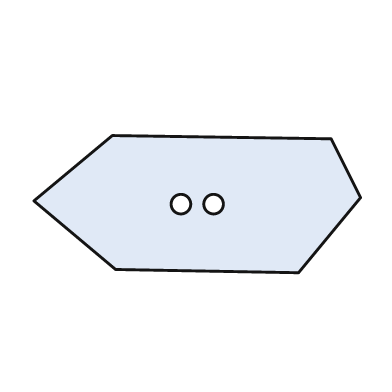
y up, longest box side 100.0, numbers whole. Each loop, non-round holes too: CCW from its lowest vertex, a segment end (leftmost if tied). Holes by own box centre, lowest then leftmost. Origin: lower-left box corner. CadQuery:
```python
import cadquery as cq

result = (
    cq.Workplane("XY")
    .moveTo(81.0, 0.0)
    .lineTo(100.0, 23.0)
    .lineTo(91.0, 41.0)
    .lineTo(24.0, 42.0)
    .lineTo(0.0, 22.0)
    .lineTo(25.0, 1.0)
    .close()
    .moveTo(45.0, 21.0)
    .circle(3.0)
    .moveTo(55.0, 21.0)
    .circle(3.0)
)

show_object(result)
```